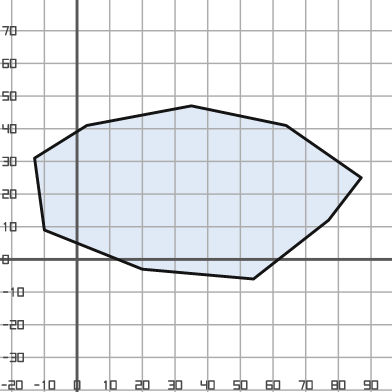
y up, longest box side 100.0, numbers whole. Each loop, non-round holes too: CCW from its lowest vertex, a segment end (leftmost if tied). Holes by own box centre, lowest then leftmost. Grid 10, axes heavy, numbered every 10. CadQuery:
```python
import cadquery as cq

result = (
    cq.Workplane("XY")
    .moveTo(54.0, -6.0)
    .lineTo(77.0, 12.0)
    .lineTo(87.0, 25.0)
    .lineTo(64.0, 41.0)
    .lineTo(35.0, 47.0)
    .lineTo(3.0, 41.0)
    .lineTo(-13.0, 31.0)
    .lineTo(-10.0, 9.0)
    .lineTo(20.0, -3.0)
    .close()
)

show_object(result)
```